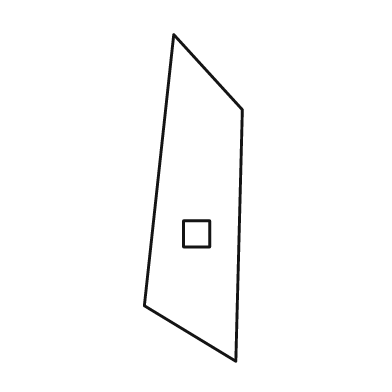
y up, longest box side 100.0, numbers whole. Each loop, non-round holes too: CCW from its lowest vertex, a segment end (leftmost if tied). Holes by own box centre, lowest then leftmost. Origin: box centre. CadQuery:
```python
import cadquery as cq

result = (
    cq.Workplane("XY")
    .moveTo(13.0, -50.0)
    .lineTo(15.0, 27.0)
    .lineTo(-6.0, 50.0)
    .lineTo(-15.0, -33.0)
    .close()
    .moveTo(-3.0, -15.0)
    .lineTo(5.0, -15.0)
    .lineTo(5.0, -7.0)
    .lineTo(-3.0, -7.0)
    .close()
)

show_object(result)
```